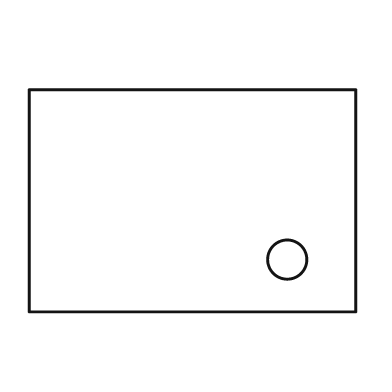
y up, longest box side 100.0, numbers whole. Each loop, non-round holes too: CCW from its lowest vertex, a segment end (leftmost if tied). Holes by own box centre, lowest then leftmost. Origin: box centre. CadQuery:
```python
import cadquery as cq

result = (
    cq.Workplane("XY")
    .moveTo(-50.0, -34.0)
    .lineTo(50.0, -34.0)
    .lineTo(50.0, 34.0)
    .lineTo(-50.0, 34.0)
    .close()
    .moveTo(29.0, -18.0)
    .circle(6.0)
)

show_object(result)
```